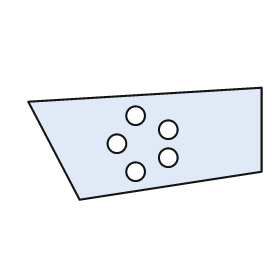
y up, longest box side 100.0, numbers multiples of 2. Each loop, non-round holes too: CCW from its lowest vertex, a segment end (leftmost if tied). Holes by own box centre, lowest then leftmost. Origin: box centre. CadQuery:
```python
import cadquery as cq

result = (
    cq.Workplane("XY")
    .moveTo(-28.0, -24.0)
    .lineTo(50.0, -12.0)
    .lineTo(50.0, 24.0)
    .lineTo(-50.0, 18.0)
    .close()
    .moveTo(-4.0, -12.0)
    .circle(4.0)
    .moveTo(10.0, -6.0)
    .circle(4.0)
    .moveTo(-12.0, 0.0)
    .circle(4.0)
    .moveTo(10.0, 6.0)
    .circle(4.0)
    .moveTo(-4.0, 12.0)
    .circle(4.0)
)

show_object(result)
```